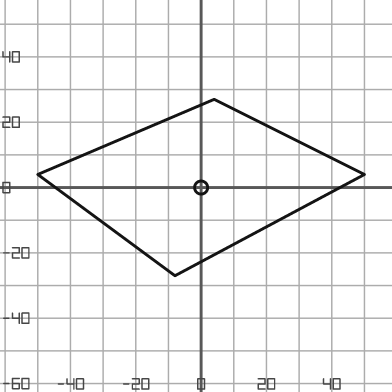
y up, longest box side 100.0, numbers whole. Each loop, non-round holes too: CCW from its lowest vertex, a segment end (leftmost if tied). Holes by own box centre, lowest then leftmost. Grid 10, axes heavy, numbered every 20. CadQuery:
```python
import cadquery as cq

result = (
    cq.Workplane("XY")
    .moveTo(-8.0, -27.0)
    .lineTo(50.0, 4.0)
    .lineTo(4.0, 27.0)
    .lineTo(-50.0, 4.0)
    .close()
    .moveTo(0.0, 0.0)
    .circle(2.0)
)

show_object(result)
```